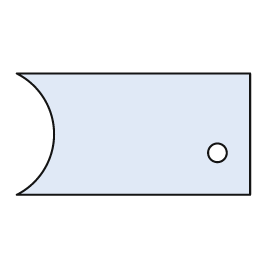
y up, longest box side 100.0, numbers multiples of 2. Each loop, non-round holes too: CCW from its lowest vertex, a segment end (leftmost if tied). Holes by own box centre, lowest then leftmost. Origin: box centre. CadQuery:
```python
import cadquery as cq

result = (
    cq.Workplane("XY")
    .moveTo(-50.0, -26.0)
    .lineTo(50.0, -26.0)
    .lineTo(50.0, 26.0)
    .lineTo(-50.0, 26.0)
    .threePointArc((-34.0, 0.0), (-50.0, -26.0))
    .close()
    .moveTo(36.0, -8.0)
    .circle(4.0)
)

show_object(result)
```